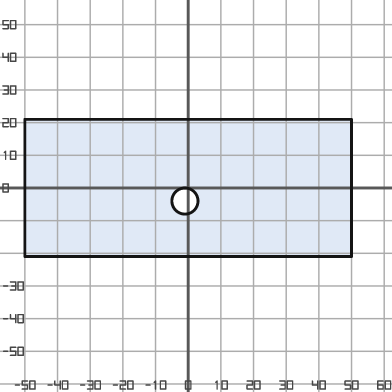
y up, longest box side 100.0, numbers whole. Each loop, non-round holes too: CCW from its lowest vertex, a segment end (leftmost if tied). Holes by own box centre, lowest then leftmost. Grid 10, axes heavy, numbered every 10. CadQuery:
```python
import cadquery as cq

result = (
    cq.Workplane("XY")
    .moveTo(-50.0, -21.0)
    .lineTo(50.0, -21.0)
    .lineTo(50.0, 21.0)
    .lineTo(-50.0, 21.0)
    .close()
    .moveTo(-1.0, -4.0)
    .circle(4.0)
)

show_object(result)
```